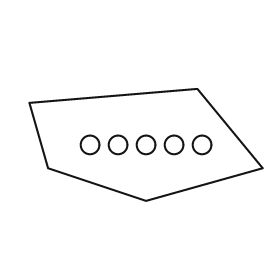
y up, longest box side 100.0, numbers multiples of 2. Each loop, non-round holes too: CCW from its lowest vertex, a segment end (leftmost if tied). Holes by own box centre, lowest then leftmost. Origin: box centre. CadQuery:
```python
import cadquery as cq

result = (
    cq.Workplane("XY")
    .moveTo(0.0, -24.0)
    .lineTo(50.0, -10.0)
    .lineTo(22.0, 24.0)
    .lineTo(-50.0, 18.0)
    .lineTo(-42.0, -10.0)
    .close()
    .moveTo(-24.0, 0.0)
    .circle(4.0)
    .moveTo(-12.0, 0.0)
    .circle(4.0)
    .moveTo(0.0, 0.0)
    .circle(4.0)
    .moveTo(12.0, 0.0)
    .circle(4.0)
    .moveTo(24.0, 0.0)
    .circle(4.0)
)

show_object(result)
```